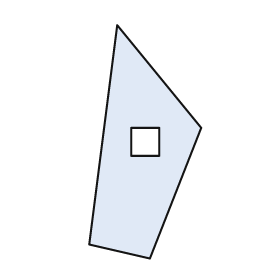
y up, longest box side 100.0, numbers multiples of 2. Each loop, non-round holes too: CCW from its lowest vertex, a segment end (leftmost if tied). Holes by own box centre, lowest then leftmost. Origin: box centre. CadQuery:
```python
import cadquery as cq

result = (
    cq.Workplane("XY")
    .moveTo(2.0, -50.0)
    .lineTo(24.0, 6.0)
    .lineTo(-12.0, 50.0)
    .lineTo(-24.0, -44.0)
    .close()
    .moveTo(-6.0, -6.0)
    .lineTo(6.0, -6.0)
    .lineTo(6.0, 6.0)
    .lineTo(-6.0, 6.0)
    .close()
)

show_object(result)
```